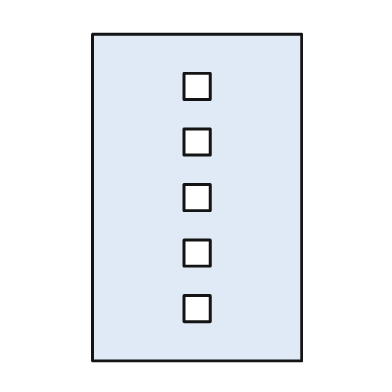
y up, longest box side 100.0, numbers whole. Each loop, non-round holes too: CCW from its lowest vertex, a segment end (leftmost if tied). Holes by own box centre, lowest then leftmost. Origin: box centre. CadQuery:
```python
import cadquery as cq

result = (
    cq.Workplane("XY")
    .moveTo(-32.0, -50.0)
    .lineTo(32.0, -50.0)
    .lineTo(32.0, 50.0)
    .lineTo(-32.0, 50.0)
    .close()
    .moveTo(-4.0, -38.0)
    .lineTo(4.0, -38.0)
    .lineTo(4.0, -30.0)
    .lineTo(-4.0, -30.0)
    .close()
    .moveTo(-4.0, -21.0)
    .lineTo(4.0, -21.0)
    .lineTo(4.0, -13.0)
    .lineTo(-4.0, -13.0)
    .close()
    .moveTo(-4.0, -4.0)
    .lineTo(4.0, -4.0)
    .lineTo(4.0, 4.0)
    .lineTo(-4.0, 4.0)
    .close()
    .moveTo(-4.0, 13.0)
    .lineTo(4.0, 13.0)
    .lineTo(4.0, 21.0)
    .lineTo(-4.0, 21.0)
    .close()
    .moveTo(-4.0, 30.0)
    .lineTo(4.0, 30.0)
    .lineTo(4.0, 38.0)
    .lineTo(-4.0, 38.0)
    .close()
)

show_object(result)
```